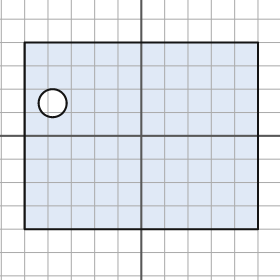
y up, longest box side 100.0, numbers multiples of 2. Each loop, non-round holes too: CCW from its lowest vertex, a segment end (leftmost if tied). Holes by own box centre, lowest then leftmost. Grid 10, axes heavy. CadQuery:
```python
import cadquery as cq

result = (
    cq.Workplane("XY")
    .moveTo(-50.0, -40.0)
    .lineTo(50.0, -40.0)
    .lineTo(50.0, 40.0)
    .lineTo(-50.0, 40.0)
    .close()
    .moveTo(-38.0, 14.0)
    .circle(6.0)
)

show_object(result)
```